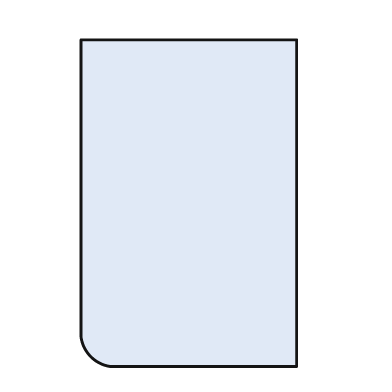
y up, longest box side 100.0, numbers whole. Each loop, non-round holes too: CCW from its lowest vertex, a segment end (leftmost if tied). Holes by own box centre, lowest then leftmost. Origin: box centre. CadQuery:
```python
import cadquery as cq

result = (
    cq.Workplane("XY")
    .moveTo(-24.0, -50.0)
    .lineTo(33.0, -50.0)
    .lineTo(33.0, 50.0)
    .lineTo(-33.0, 50.0)
    .lineTo(-33.0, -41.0)
    .threePointArc((-30.0, -47.0), (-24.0, -50.0))
    .close()
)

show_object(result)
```